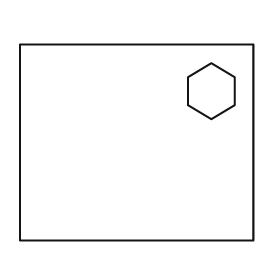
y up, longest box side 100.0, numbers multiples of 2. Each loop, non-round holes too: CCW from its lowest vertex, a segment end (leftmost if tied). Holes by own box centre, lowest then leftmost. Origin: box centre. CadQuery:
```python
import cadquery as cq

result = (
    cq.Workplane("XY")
    .moveTo(-50.0, -42.0)
    .lineTo(50.0, -42.0)
    .lineTo(50.0, 42.0)
    .lineTo(-50.0, 42.0)
    .close()
    .moveTo(32.0, 10.0)
    .lineTo(42.0, 16.0)
    .lineTo(42.0, 28.0)
    .lineTo(32.0, 34.0)
    .lineTo(22.0, 28.0)
    .lineTo(22.0, 16.0)
    .close()
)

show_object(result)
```